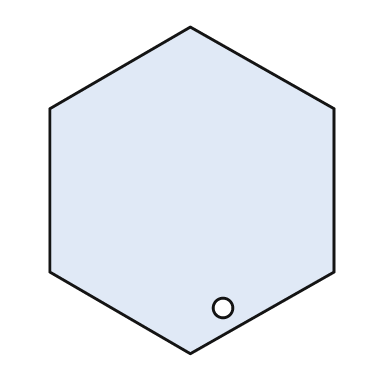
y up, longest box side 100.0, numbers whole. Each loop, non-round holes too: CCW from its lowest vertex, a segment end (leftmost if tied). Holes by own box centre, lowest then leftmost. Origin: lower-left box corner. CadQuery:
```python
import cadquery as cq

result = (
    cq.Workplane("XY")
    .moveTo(43.0, 0.0)
    .lineTo(87.0, 25.0)
    .lineTo(87.0, 75.0)
    .lineTo(43.0, 100.0)
    .lineTo(0.0, 75.0)
    .lineTo(0.0, 25.0)
    .close()
    .moveTo(53.0, 14.0)
    .circle(3.0)
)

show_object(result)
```